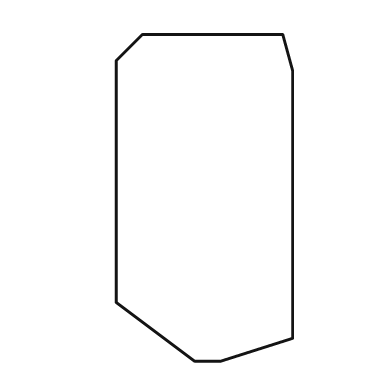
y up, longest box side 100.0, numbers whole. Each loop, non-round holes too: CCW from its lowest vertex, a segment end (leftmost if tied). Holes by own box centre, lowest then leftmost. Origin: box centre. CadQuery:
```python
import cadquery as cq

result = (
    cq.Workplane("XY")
    .moveTo(-3.0, -50.0)
    .lineTo(5.0, -50.0)
    .lineTo(27.0, -43.0)
    .lineTo(27.0, 39.0)
    .lineTo(24.0, 50.0)
    .lineTo(-19.0, 50.0)
    .lineTo(-27.0, 42.0)
    .lineTo(-27.0, -32.0)
    .close()
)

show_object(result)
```